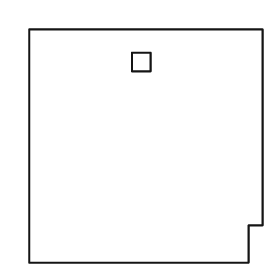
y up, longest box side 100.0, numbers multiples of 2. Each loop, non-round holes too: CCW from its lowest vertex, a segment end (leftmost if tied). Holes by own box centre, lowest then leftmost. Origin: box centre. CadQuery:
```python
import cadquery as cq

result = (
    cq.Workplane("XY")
    .moveTo(-50.0, -50.0)
    .lineTo(44.0, -50.0)
    .lineTo(44.0, -34.0)
    .lineTo(50.0, -34.0)
    .lineTo(50.0, 50.0)
    .lineTo(-50.0, 50.0)
    .close()
    .moveTo(-6.0, 32.0)
    .lineTo(2.0, 32.0)
    .lineTo(2.0, 40.0)
    .lineTo(-6.0, 40.0)
    .close()
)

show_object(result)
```